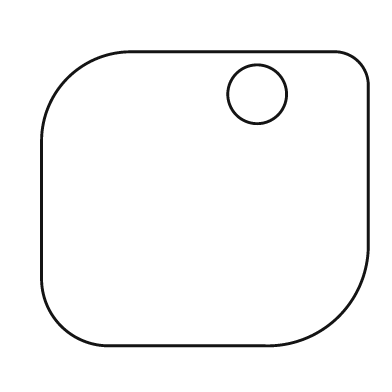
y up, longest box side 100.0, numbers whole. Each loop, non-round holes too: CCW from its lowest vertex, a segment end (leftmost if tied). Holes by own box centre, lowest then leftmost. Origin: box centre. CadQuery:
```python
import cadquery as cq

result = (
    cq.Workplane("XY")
    .moveTo(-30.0, -45.0)
    .lineTo(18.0, -45.0)
    .threePointArc((41.0, -36.0), (50.0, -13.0))
    .lineTo(50.0, 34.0)
    .threePointArc((47.0, 42.0), (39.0, 45.0))
    .lineTo(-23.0, 45.0)
    .threePointArc((-42.0, 37.0), (-50.0, 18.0))
    .lineTo(-50.0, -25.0)
    .threePointArc((-44.0, -39.0), (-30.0, -45.0))
    .close()
    .moveTo(16.0, 32.0)
    .circle(9.0)
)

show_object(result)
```